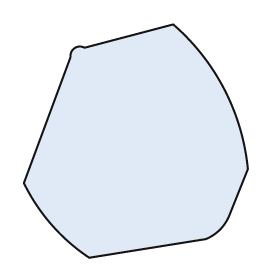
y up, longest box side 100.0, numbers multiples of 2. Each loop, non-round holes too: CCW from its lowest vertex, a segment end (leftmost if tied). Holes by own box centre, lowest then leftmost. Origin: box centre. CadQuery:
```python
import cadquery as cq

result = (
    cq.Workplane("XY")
    .moveTo(-20.0, -50.0)
    .lineTo(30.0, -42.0)
    .threePointArc((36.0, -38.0), (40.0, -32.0))
    .lineTo(48.0, -12.0)
    .threePointArc((38.0, 22.0), (16.0, 50.0))
    .lineTo(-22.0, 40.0)
    .threePointArc((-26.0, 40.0), (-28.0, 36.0))
    .lineTo(-48.0, -18.0)
    .threePointArc((-36.0, -36.0), (-20.0, -50.0))
    .close()
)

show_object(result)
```